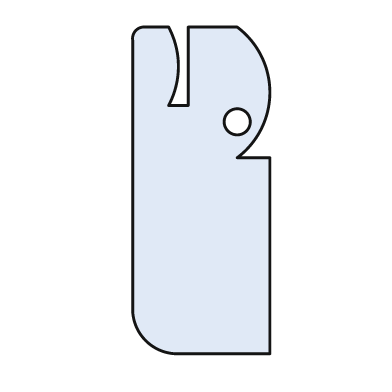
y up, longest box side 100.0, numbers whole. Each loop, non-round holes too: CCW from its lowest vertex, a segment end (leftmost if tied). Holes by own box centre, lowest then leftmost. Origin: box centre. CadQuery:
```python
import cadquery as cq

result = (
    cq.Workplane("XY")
    .moveTo(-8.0, -50.0)
    .lineTo(21.0, -50.0)
    .lineTo(21.0, 10.0)
    .lineTo(11.0, 10.0)
    .threePointArc((21.0, 30.0), (11.0, 50.0))
    .lineTo(-4.0, 50.0)
    .lineTo(-4.0, 26.0)
    .lineTo(-10.0, 26.0)
    .threePointArc((-7.0, 38.0), (-10.0, 50.0))
    .lineTo(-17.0, 50.0)
    .threePointArc((-20.0, 49.0), (-21.0, 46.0))
    .lineTo(-21.0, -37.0)
    .threePointArc((-17.0, -46.0), (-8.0, -50.0))
    .close()
    .moveTo(11.0, 21.0)
    .circle(4.0)
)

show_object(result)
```